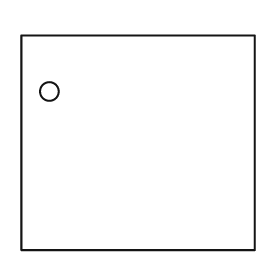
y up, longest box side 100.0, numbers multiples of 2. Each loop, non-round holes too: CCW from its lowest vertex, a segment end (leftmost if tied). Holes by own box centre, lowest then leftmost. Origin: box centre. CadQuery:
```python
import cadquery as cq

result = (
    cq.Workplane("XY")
    .moveTo(-50.0, -46.0)
    .lineTo(50.0, -46.0)
    .lineTo(50.0, 46.0)
    .lineTo(-50.0, 46.0)
    .close()
    .moveTo(-38.0, 22.0)
    .circle(4.0)
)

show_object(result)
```